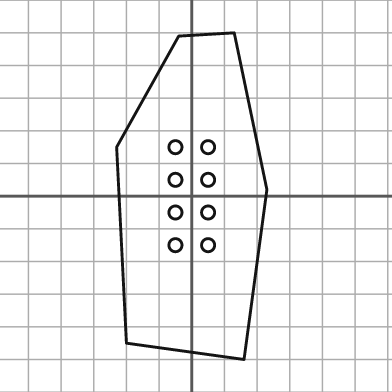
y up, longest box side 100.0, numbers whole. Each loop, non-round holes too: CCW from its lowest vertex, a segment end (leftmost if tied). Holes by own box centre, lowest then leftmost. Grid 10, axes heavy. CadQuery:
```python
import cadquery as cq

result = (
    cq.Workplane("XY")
    .moveTo(16.0, -50.0)
    .lineTo(23.0, 2.0)
    .lineTo(13.0, 50.0)
    .lineTo(-4.0, 49.0)
    .lineTo(-23.0, 15.0)
    .lineTo(-20.0, -45.0)
    .close()
    .moveTo(-5.0, -15.0)
    .circle(2.0)
    .moveTo(5.0, -15.0)
    .circle(2.0)
    .moveTo(-5.0, -5.0)
    .circle(2.0)
    .moveTo(5.0, -5.0)
    .circle(2.0)
    .moveTo(-5.0, 5.0)
    .circle(2.0)
    .moveTo(5.0, 5.0)
    .circle(2.0)
    .moveTo(-5.0, 15.0)
    .circle(2.0)
    .moveTo(5.0, 15.0)
    .circle(2.0)
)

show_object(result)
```